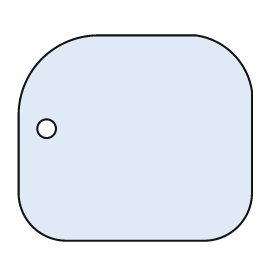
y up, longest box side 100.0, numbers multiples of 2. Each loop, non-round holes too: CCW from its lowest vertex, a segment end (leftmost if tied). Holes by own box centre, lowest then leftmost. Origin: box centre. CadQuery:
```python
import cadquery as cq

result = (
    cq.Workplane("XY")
    .moveTo(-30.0, -44.0)
    .lineTo(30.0, -44.0)
    .threePointArc((44.0, -38.0), (50.0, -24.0))
    .lineTo(50.0, 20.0)
    .threePointArc((42.0, 36.0), (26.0, 44.0))
    .lineTo(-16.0, 44.0)
    .threePointArc((-40.0, 34.0), (-50.0, 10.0))
    .lineTo(-50.0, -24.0)
    .threePointArc((-44.0, -38.0), (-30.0, -44.0))
    .close()
    .moveTo(-38.0, 4.0)
    .circle(4.0)
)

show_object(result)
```